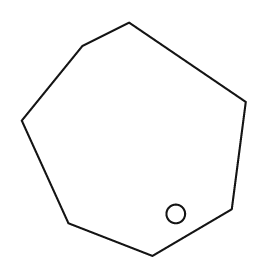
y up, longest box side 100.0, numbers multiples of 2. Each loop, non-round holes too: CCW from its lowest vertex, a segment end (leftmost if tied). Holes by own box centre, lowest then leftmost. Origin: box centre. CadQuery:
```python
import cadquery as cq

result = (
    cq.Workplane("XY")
    .moveTo(8.0, -50.0)
    .lineTo(42.0, -30.0)
    .lineTo(48.0, 16.0)
    .lineTo(-2.0, 50.0)
    .lineTo(-22.0, 40.0)
    .lineTo(-48.0, 8.0)
    .lineTo(-28.0, -36.0)
    .close()
    .moveTo(18.0, -32.0)
    .circle(4.0)
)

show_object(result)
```